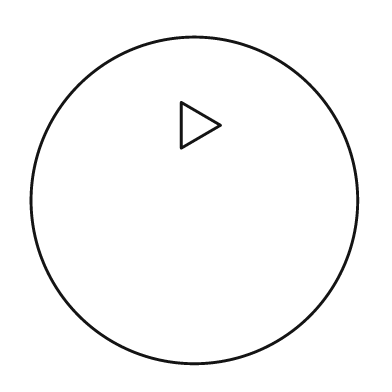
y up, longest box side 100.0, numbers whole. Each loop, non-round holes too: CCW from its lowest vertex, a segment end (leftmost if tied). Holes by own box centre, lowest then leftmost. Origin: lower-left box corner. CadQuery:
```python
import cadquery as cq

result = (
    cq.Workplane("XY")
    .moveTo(50.0, 50.0)
    .circle(50.0)
    .moveTo(46.0, 66.0)
    .lineTo(58.0, 73.0)
    .lineTo(46.0, 80.0)
    .close()
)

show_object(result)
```